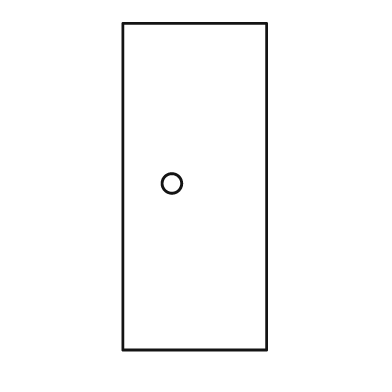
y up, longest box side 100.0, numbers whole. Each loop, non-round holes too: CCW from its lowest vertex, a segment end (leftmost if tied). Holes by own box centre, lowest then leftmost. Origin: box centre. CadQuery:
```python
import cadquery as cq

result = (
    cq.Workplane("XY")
    .moveTo(-22.0, -50.0)
    .lineTo(22.0, -50.0)
    .lineTo(22.0, 50.0)
    .lineTo(-22.0, 50.0)
    .close()
    .moveTo(-7.0, 1.0)
    .circle(3.0)
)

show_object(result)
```